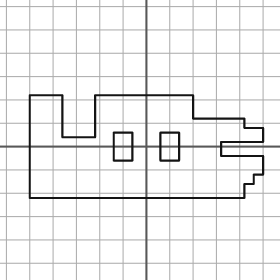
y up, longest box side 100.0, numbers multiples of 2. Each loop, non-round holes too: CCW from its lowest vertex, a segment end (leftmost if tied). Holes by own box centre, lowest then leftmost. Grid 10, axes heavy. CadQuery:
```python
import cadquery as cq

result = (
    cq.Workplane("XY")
    .moveTo(-50.0, -22.0)
    .lineTo(42.0, -22.0)
    .lineTo(42.0, -16.0)
    .lineTo(46.0, -16.0)
    .lineTo(46.0, -12.0)
    .lineTo(50.0, -12.0)
    .lineTo(50.0, -4.0)
    .lineTo(32.0, -4.0)
    .lineTo(32.0, 2.0)
    .lineTo(50.0, 2.0)
    .lineTo(50.0, 8.0)
    .lineTo(42.0, 8.0)
    .lineTo(42.0, 12.0)
    .lineTo(20.0, 12.0)
    .lineTo(20.0, 22.0)
    .lineTo(-22.0, 22.0)
    .lineTo(-22.0, 4.0)
    .lineTo(-36.0, 4.0)
    .lineTo(-36.0, 22.0)
    .lineTo(-50.0, 22.0)
    .close()
    .moveTo(-14.0, -6.0)
    .lineTo(-6.0, -6.0)
    .lineTo(-6.0, 6.0)
    .lineTo(-14.0, 6.0)
    .close()
    .moveTo(6.0, -6.0)
    .lineTo(14.0, -6.0)
    .lineTo(14.0, 6.0)
    .lineTo(6.0, 6.0)
    .close()
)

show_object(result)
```